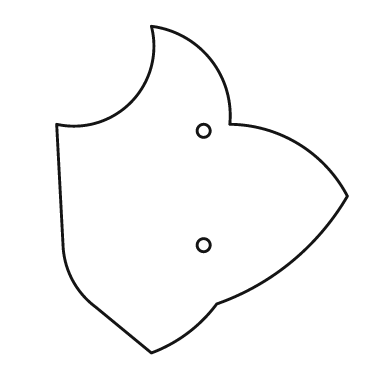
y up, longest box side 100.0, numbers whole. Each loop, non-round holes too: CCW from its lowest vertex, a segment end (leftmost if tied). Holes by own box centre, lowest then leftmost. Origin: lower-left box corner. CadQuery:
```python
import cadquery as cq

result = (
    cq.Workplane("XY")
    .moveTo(29.0, 0.0)
    .threePointArc((40.0, 6.0), (49.0, 15.0))
    .threePointArc((72.0, 28.0), (89.0, 48.0))
    .threePointArc((74.0, 64.0), (53.0, 70.0))
    .threePointArc((47.0, 90.0), (29.0, 100.0))
    .threePointArc((23.0, 77.0), (0.0, 70.0))
    .lineTo(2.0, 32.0)
    .threePointArc((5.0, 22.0), (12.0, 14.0))
    .close()
    .moveTo(45.0, 33.0)
    .circle(2.0)
    .moveTo(45.0, 68.0)
    .circle(2.0)
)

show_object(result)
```